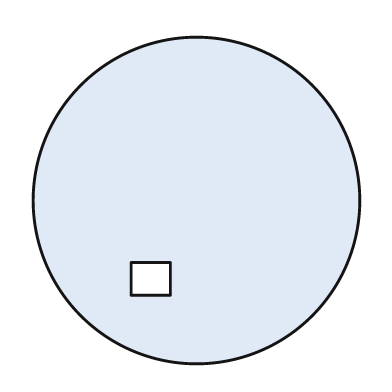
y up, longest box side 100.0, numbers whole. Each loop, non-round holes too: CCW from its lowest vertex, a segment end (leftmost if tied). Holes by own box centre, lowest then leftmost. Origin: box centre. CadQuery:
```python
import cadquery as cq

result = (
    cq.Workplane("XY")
    .moveTo(0.0, 0.0)
    .circle(50.0)
    .moveTo(-20.0, -29.0)
    .lineTo(-8.0, -29.0)
    .lineTo(-8.0, -19.0)
    .lineTo(-20.0, -19.0)
    .close()
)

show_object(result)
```